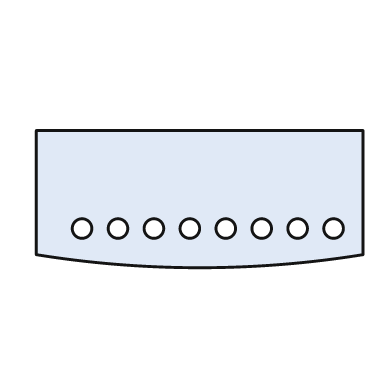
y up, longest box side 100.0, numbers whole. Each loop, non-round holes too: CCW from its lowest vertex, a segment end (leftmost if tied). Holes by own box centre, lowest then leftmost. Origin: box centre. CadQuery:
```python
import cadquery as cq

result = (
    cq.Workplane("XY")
    .moveTo(-50.0, -17.0)
    .threePointArc((0.0, -21.0), (50.0, -17.0))
    .lineTo(50.0, 21.0)
    .lineTo(-50.0, 21.0)
    .close()
    .moveTo(-36.0, -9.0)
    .circle(3.0)
    .moveTo(-25.0, -9.0)
    .circle(3.0)
    .moveTo(-14.0, -9.0)
    .circle(3.0)
    .moveTo(-3.0, -9.0)
    .circle(3.0)
    .moveTo(8.0, -9.0)
    .circle(3.0)
    .moveTo(19.0, -9.0)
    .circle(3.0)
    .moveTo(30.0, -9.0)
    .circle(3.0)
    .moveTo(41.0, -9.0)
    .circle(3.0)
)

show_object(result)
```